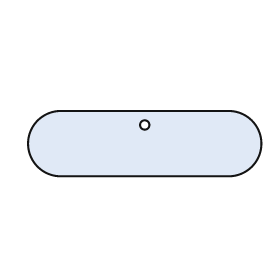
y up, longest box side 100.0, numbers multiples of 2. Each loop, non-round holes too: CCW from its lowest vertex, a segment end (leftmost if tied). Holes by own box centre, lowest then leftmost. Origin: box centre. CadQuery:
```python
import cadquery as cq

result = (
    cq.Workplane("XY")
    .moveTo(-36.0, -14.0)
    .lineTo(36.0, -14.0)
    .threePointArc((50.0, 0.0), (36.0, 14.0))
    .lineTo(-36.0, 14.0)
    .threePointArc((-50.0, 0.0), (-36.0, -14.0))
    .close()
    .moveTo(0.0, 8.0)
    .circle(2.0)
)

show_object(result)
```